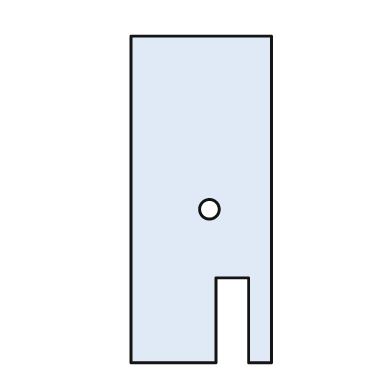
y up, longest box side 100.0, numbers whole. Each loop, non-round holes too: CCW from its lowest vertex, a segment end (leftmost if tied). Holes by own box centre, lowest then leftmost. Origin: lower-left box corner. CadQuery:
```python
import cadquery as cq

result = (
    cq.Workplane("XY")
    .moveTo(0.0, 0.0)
    .lineTo(26.0, 0.0)
    .lineTo(26.0, 26.0)
    .lineTo(36.0, 26.0)
    .lineTo(36.0, 0.0)
    .lineTo(43.0, 0.0)
    .lineTo(43.0, 100.0)
    .lineTo(0.0, 100.0)
    .close()
    .moveTo(24.0, 47.0)
    .circle(3.0)
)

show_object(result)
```